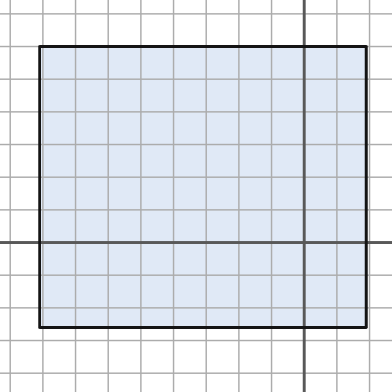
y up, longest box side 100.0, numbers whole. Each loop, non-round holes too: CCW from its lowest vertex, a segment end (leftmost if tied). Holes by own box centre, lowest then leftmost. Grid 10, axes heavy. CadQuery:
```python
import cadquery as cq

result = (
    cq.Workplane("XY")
    .moveTo(-81.0, -26.0)
    .lineTo(19.0, -26.0)
    .lineTo(19.0, 60.0)
    .lineTo(-81.0, 60.0)
    .close()
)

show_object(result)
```